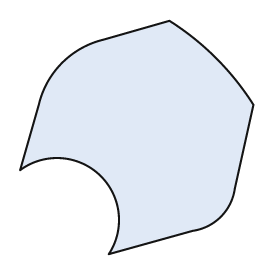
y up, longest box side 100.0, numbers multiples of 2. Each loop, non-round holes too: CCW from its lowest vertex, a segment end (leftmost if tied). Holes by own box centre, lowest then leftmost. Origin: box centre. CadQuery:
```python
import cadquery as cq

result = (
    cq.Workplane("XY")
    .moveTo(-12.0, -50.0)
    .lineTo(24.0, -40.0)
    .threePointArc((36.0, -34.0), (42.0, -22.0))
    .lineTo(50.0, 14.0)
    .threePointArc((34.0, 34.0), (14.0, 50.0))
    .lineTo(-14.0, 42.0)
    .threePointArc((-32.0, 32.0), (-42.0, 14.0))
    .lineTo(-50.0, -14.0)
    .threePointArc((-16.0, -16.0), (-12.0, -50.0))
    .close()
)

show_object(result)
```